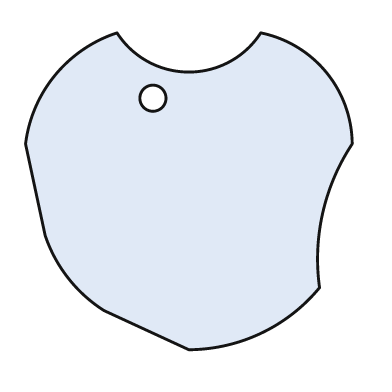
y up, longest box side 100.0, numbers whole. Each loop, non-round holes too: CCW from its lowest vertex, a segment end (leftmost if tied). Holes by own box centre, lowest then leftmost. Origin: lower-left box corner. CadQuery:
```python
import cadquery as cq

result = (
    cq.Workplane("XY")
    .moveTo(50.0, 0.0)
    .threePointArc((72.0, 5.0), (90.0, 19.0))
    .threePointArc((91.0, 42.0), (100.0, 63.0))
    .threePointArc((92.0, 85.0), (72.0, 97.0))
    .threePointArc((50.0, 85.0), (28.0, 97.0))
    .threePointArc((9.0, 84.0), (0.0, 63.0))
    .lineTo(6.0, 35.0)
    .threePointArc((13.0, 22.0), (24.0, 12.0))
    .close()
    .moveTo(39.0, 77.0)
    .circle(4.0)
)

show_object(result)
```